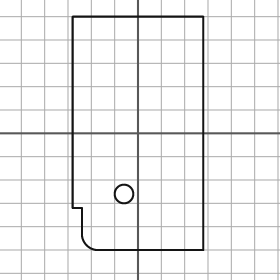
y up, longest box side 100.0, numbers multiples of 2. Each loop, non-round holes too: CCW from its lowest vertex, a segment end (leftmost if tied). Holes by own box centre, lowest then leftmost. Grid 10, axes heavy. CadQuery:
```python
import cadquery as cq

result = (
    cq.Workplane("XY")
    .moveTo(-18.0, -50.0)
    .lineTo(28.0, -50.0)
    .lineTo(28.0, 50.0)
    .lineTo(-28.0, 50.0)
    .lineTo(-28.0, -32.0)
    .lineTo(-24.0, -32.0)
    .lineTo(-24.0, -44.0)
    .threePointArc((-22.0, -48.0), (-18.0, -50.0))
    .close()
    .moveTo(-6.0, -26.0)
    .circle(4.0)
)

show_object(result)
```